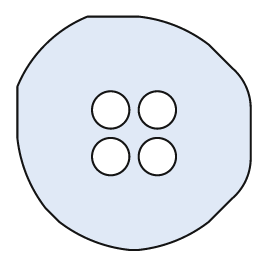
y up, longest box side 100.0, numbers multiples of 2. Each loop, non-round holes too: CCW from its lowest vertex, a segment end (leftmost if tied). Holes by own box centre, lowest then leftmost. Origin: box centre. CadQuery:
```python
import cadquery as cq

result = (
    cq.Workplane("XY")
    .moveTo(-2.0, -50.0)
    .lineTo(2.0, -50.0)
    .threePointArc((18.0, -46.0), (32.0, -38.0))
    .lineTo(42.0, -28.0)
    .threePointArc((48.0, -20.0), (50.0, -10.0))
    .lineTo(50.0, 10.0)
    .threePointArc((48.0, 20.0), (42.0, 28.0))
    .lineTo(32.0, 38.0)
    .threePointArc((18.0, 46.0), (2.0, 50.0))
    .lineTo(-20.0, 50.0)
    .threePointArc((-38.0, 38.0), (-50.0, 20.0))
    .lineTo(-50.0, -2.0)
    .threePointArc((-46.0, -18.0), (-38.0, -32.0))
    .lineTo(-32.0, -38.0)
    .threePointArc((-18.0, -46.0), (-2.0, -50.0))
    .close()
    .moveTo(-10.0, -10.0)
    .circle(8.0)
    .moveTo(10.0, -10.0)
    .circle(8.0)
    .moveTo(-10.0, 10.0)
    .circle(8.0)
    .moveTo(10.0, 10.0)
    .circle(8.0)
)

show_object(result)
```